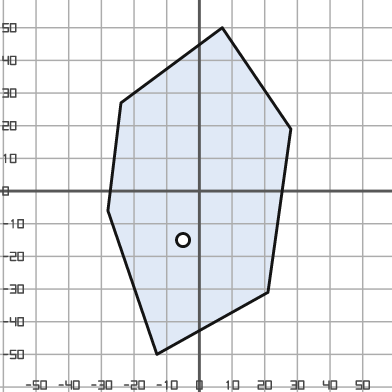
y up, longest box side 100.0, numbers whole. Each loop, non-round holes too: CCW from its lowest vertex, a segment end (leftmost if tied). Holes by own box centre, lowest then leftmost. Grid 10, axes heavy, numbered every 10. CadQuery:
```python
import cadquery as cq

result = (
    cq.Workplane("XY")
    .moveTo(-13.0, -50.0)
    .lineTo(21.0, -31.0)
    .lineTo(28.0, 19.0)
    .lineTo(7.0, 50.0)
    .lineTo(-24.0, 27.0)
    .lineTo(-28.0, -6.0)
    .close()
    .moveTo(-5.0, -15.0)
    .circle(2.0)
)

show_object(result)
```